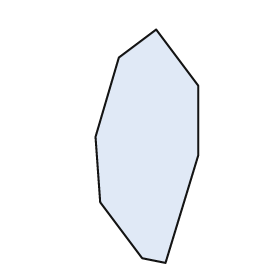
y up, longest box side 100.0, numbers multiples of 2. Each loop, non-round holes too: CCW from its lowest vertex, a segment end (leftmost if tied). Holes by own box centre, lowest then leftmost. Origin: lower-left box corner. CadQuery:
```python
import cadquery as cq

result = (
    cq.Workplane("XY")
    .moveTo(30.0, 0.0)
    .lineTo(44.0, 46.0)
    .lineTo(44.0, 76.0)
    .lineTo(26.0, 100.0)
    .lineTo(10.0, 88.0)
    .lineTo(0.0, 54.0)
    .lineTo(2.0, 26.0)
    .lineTo(20.0, 2.0)
    .close()
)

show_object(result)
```